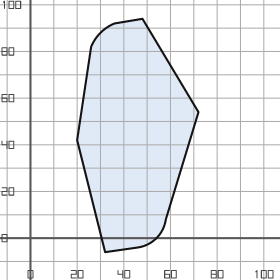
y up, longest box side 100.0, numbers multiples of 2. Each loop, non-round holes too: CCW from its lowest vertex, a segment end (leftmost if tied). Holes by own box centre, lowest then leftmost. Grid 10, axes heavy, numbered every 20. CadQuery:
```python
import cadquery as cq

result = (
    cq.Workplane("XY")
    .moveTo(32.0, -6.0)
    .lineTo(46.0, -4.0)
    .threePointArc((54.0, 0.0), (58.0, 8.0))
    .lineTo(72.0, 54.0)
    .lineTo(48.0, 94.0)
    .lineTo(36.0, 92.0)
    .threePointArc((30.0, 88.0), (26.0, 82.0))
    .lineTo(20.0, 42.0)
    .close()
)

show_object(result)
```